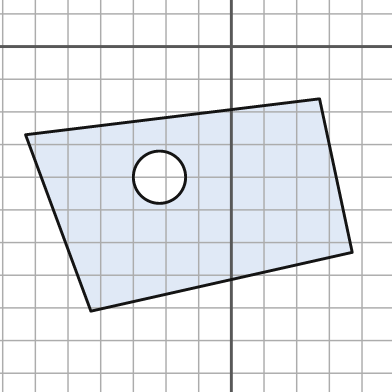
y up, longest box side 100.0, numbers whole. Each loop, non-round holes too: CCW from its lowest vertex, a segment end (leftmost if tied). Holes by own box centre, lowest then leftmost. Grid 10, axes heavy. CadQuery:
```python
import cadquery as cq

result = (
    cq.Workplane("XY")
    .moveTo(-43.0, -81.0)
    .lineTo(37.0, -63.0)
    .lineTo(27.0, -16.0)
    .lineTo(-63.0, -27.0)
    .close()
    .moveTo(-22.0, -40.0)
    .circle(8.0)
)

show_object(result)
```